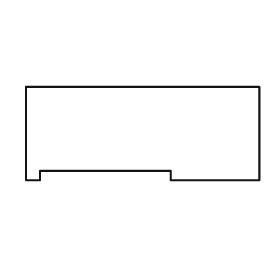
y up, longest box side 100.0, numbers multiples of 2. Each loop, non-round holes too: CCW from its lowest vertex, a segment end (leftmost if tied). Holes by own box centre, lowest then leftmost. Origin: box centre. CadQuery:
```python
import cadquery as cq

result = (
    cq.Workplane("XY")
    .moveTo(-50.0, -20.0)
    .lineTo(-44.0, -20.0)
    .lineTo(-44.0, -16.0)
    .lineTo(12.0, -16.0)
    .lineTo(12.0, -20.0)
    .lineTo(50.0, -20.0)
    .lineTo(50.0, 20.0)
    .lineTo(-50.0, 20.0)
    .close()
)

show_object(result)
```